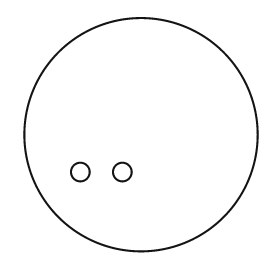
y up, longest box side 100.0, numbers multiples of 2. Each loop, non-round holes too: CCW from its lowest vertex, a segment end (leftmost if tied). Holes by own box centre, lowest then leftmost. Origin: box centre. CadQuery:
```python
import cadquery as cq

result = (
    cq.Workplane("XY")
    .moveTo(0.0, 0.0)
    .circle(50.0)
    .moveTo(-26.0, -16.0)
    .circle(4.0)
    .moveTo(-8.0, -16.0)
    .circle(4.0)
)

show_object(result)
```